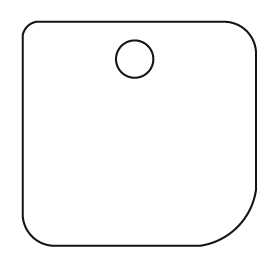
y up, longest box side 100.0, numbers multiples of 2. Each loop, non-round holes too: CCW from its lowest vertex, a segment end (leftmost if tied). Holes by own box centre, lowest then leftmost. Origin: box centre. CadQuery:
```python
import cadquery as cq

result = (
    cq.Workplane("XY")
    .moveTo(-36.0, -48.0)
    .lineTo(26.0, -48.0)
    .threePointArc((42.0, -40.0), (50.0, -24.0))
    .lineTo(50.0, 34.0)
    .threePointArc((46.0, 44.0), (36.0, 48.0))
    .lineTo(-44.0, 48.0)
    .threePointArc((-48.0, 46.0), (-50.0, 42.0))
    .lineTo(-50.0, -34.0)
    .threePointArc((-46.0, -44.0), (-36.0, -48.0))
    .close()
    .moveTo(-2.0, 32.0)
    .circle(8.0)
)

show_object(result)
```